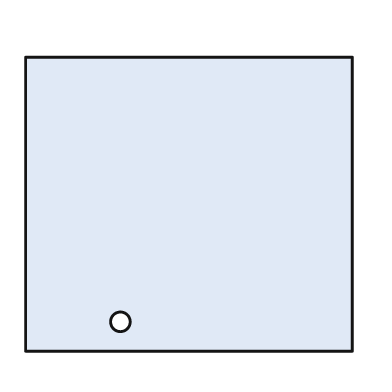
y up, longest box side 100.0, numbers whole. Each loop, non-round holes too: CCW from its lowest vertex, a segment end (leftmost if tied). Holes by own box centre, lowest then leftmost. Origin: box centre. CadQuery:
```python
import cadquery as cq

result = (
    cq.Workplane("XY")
    .moveTo(-50.0, -45.0)
    .lineTo(50.0, -45.0)
    .lineTo(50.0, 45.0)
    .lineTo(-50.0, 45.0)
    .close()
    .moveTo(-21.0, -36.0)
    .circle(3.0)
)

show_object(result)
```